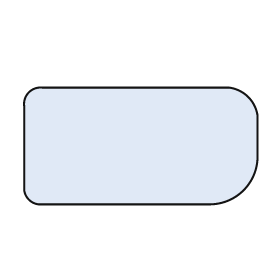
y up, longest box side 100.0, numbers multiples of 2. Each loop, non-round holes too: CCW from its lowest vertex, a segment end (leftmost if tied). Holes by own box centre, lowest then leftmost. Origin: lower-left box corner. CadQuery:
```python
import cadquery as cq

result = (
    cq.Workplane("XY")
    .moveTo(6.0, 0.0)
    .lineTo(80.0, 0.0)
    .threePointArc((94.0, 6.0), (100.0, 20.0))
    .lineTo(100.0, 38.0)
    .threePointArc((96.0, 46.0), (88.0, 50.0))
    .lineTo(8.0, 50.0)
    .threePointArc((2.0, 48.0), (0.0, 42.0))
    .lineTo(0.0, 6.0)
    .threePointArc((2.0, 2.0), (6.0, 0.0))
    .close()
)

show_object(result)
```